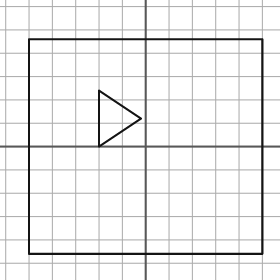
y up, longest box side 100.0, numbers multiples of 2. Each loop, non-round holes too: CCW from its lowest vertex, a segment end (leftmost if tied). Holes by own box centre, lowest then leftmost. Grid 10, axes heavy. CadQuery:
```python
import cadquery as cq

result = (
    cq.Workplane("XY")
    .moveTo(-50.0, -46.0)
    .lineTo(50.0, -46.0)
    .lineTo(50.0, 46.0)
    .lineTo(-50.0, 46.0)
    .close()
    .moveTo(-20.0, 0.0)
    .lineTo(-2.0, 12.0)
    .lineTo(-20.0, 24.0)
    .close()
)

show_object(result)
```